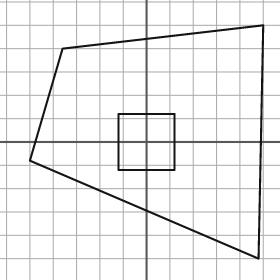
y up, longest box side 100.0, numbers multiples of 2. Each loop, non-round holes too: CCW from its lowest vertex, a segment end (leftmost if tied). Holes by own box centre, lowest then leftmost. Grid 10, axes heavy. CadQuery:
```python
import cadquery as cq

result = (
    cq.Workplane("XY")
    .moveTo(48.0, -50.0)
    .lineTo(50.0, 50.0)
    .lineTo(-36.0, 40.0)
    .lineTo(-50.0, -8.0)
    .close()
    .moveTo(-12.0, -12.0)
    .lineTo(12.0, -12.0)
    .lineTo(12.0, 12.0)
    .lineTo(-12.0, 12.0)
    .close()
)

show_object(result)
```